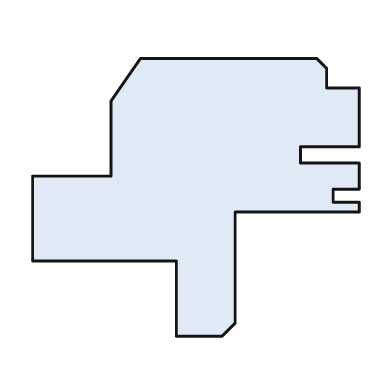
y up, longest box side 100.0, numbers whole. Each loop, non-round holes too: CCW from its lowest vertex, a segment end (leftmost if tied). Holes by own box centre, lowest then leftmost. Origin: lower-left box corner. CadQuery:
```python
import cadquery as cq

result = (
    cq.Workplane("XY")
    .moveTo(44.0, 0.0)
    .lineTo(58.0, 0.0)
    .lineTo(62.0, 4.0)
    .lineTo(62.0, 38.0)
    .lineTo(100.0, 38.0)
    .lineTo(100.0, 41.0)
    .lineTo(92.0, 41.0)
    .lineTo(92.0, 45.0)
    .lineTo(100.0, 45.0)
    .lineTo(100.0, 53.0)
    .lineTo(82.0, 53.0)
    .lineTo(82.0, 58.0)
    .lineTo(100.0, 58.0)
    .lineTo(100.0, 76.0)
    .lineTo(90.0, 76.0)
    .lineTo(90.0, 82.0)
    .lineTo(87.0, 85.0)
    .lineTo(33.0, 85.0)
    .lineTo(24.0, 72.0)
    .lineTo(24.0, 49.0)
    .lineTo(0.0, 49.0)
    .lineTo(0.0, 23.0)
    .lineTo(44.0, 23.0)
    .close()
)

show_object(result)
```